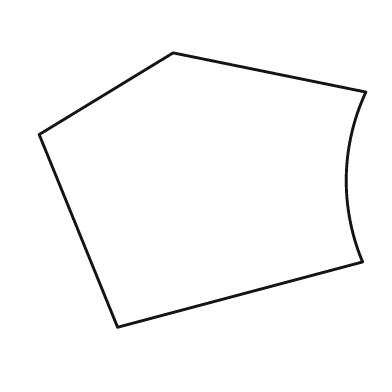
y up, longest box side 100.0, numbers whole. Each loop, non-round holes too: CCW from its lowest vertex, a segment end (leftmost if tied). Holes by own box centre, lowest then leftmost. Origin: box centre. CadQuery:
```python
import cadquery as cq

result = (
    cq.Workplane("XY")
    .moveTo(-26.0, -42.0)
    .lineTo(49.0, -22.0)
    .threePointArc((44.0, 4.0), (50.0, 30.0))
    .lineTo(-9.0, 42.0)
    .lineTo(-50.0, 17.0)
    .close()
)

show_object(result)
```